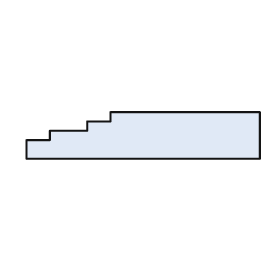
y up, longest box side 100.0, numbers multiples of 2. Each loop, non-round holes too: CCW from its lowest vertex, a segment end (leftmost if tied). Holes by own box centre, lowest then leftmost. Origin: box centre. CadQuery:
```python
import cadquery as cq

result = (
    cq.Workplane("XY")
    .moveTo(-50.0, -10.0)
    .lineTo(50.0, -10.0)
    .lineTo(50.0, 10.0)
    .lineTo(-14.0, 10.0)
    .lineTo(-14.0, 6.0)
    .lineTo(-24.0, 6.0)
    .lineTo(-24.0, 2.0)
    .lineTo(-40.0, 2.0)
    .lineTo(-40.0, -2.0)
    .lineTo(-50.0, -2.0)
    .close()
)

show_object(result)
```